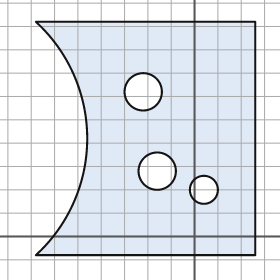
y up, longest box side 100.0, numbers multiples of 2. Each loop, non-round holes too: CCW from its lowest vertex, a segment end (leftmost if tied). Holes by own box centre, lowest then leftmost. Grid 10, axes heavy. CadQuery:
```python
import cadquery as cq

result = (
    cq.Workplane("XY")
    .moveTo(-68.0, -8.0)
    .lineTo(26.0, -8.0)
    .lineTo(26.0, 92.0)
    .lineTo(-68.0, 92.0)
    .threePointArc((-46.0, 42.0), (-68.0, -8.0))
    .close()
    .moveTo(4.0, 20.0)
    .circle(6.0)
    .moveTo(-16.0, 28.0)
    .circle(8.0)
    .moveTo(-22.0, 62.0)
    .circle(8.0)
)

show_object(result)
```